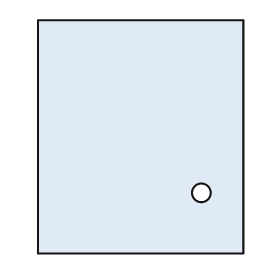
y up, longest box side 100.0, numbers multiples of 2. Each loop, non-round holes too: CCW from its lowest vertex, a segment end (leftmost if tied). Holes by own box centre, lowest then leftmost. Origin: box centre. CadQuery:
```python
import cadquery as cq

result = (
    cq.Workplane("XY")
    .moveTo(-44.0, -50.0)
    .lineTo(44.0, -50.0)
    .lineTo(44.0, 50.0)
    .lineTo(-44.0, 50.0)
    .close()
    .moveTo(26.0, -24.0)
    .circle(4.0)
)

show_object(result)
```